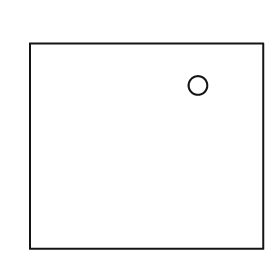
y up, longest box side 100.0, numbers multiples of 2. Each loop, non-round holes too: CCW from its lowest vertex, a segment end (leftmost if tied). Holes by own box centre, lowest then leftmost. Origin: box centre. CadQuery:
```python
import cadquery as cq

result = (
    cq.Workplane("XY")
    .moveTo(-50.0, -44.0)
    .lineTo(50.0, -44.0)
    .lineTo(50.0, 44.0)
    .lineTo(-50.0, 44.0)
    .close()
    .moveTo(22.0, 26.0)
    .circle(4.0)
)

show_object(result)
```